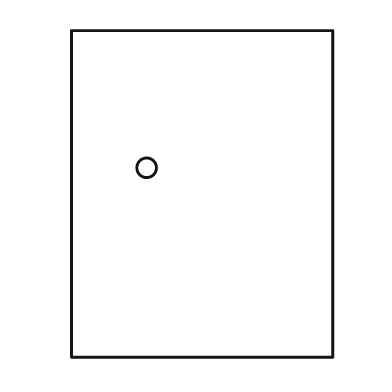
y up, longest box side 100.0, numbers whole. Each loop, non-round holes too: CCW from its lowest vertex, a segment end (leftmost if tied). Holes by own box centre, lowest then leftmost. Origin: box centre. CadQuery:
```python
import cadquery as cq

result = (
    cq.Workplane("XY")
    .moveTo(-40.0, -50.0)
    .lineTo(40.0, -50.0)
    .lineTo(40.0, 50.0)
    .lineTo(-40.0, 50.0)
    .close()
    .moveTo(-17.0, 8.0)
    .circle(3.0)
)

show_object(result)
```